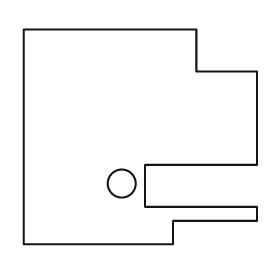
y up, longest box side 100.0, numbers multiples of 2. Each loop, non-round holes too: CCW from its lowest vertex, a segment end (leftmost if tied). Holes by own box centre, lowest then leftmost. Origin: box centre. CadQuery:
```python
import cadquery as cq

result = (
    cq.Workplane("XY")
    .moveTo(-50.0, -46.0)
    .lineTo(14.0, -46.0)
    .lineTo(14.0, -36.0)
    .lineTo(50.0, -36.0)
    .lineTo(50.0, -30.0)
    .lineTo(2.0, -30.0)
    .lineTo(2.0, -12.0)
    .lineTo(50.0, -12.0)
    .lineTo(50.0, 28.0)
    .lineTo(24.0, 28.0)
    .lineTo(24.0, 46.0)
    .lineTo(-50.0, 46.0)
    .close()
    .moveTo(-8.0, -20.0)
    .circle(6.0)
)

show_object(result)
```